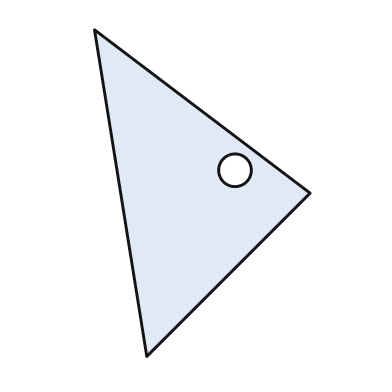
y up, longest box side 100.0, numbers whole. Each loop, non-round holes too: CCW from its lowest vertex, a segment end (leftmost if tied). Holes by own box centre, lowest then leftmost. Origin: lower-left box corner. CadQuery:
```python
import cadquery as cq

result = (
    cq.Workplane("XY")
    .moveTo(16.0, 0.0)
    .lineTo(66.0, 50.0)
    .lineTo(0.0, 100.0)
    .close()
    .moveTo(43.0, 57.0)
    .circle(5.0)
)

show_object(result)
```